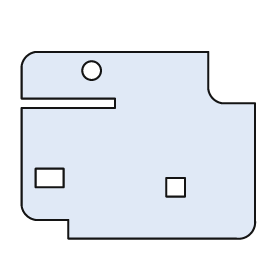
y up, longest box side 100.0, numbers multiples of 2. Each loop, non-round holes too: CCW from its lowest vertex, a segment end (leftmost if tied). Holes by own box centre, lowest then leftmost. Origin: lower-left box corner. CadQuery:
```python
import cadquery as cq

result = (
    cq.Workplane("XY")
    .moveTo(20.0, 0.0)
    .lineTo(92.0, 0.0)
    .threePointArc((98.0, 2.0), (100.0, 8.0))
    .lineTo(100.0, 58.0)
    .lineTo(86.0, 58.0)
    .threePointArc((82.0, 60.0), (80.0, 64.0))
    .lineTo(80.0, 80.0)
    .lineTo(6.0, 80.0)
    .threePointArc((2.0, 78.0), (0.0, 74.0))
    .lineTo(0.0, 60.0)
    .lineTo(40.0, 60.0)
    .lineTo(40.0, 56.0)
    .lineTo(0.0, 56.0)
    .lineTo(0.0, 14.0)
    .threePointArc((2.0, 10.0), (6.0, 8.0))
    .lineTo(20.0, 8.0)
    .close()
    .moveTo(62.0, 18.0)
    .lineTo(70.0, 18.0)
    .lineTo(70.0, 26.0)
    .lineTo(62.0, 26.0)
    .close()
    .moveTo(6.0, 22.0)
    .lineTo(18.0, 22.0)
    .lineTo(18.0, 30.0)
    .lineTo(6.0, 30.0)
    .close()
    .moveTo(30.0, 72.0)
    .circle(4.0)
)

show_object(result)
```